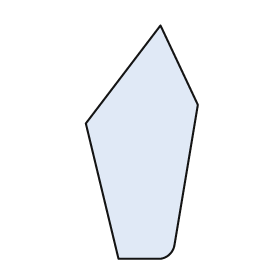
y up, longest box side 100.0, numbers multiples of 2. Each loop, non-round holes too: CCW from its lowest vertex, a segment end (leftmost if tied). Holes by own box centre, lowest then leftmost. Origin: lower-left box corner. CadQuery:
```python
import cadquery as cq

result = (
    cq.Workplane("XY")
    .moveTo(14.0, 0.0)
    .lineTo(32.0, 0.0)
    .threePointArc((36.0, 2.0), (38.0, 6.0))
    .lineTo(48.0, 66.0)
    .lineTo(32.0, 100.0)
    .lineTo(0.0, 58.0)
    .close()
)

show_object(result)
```